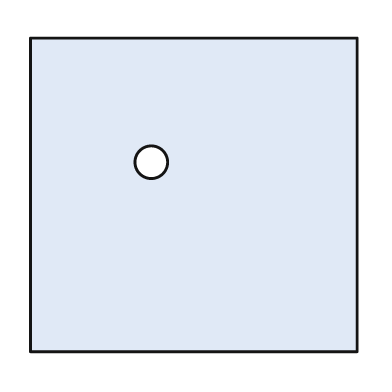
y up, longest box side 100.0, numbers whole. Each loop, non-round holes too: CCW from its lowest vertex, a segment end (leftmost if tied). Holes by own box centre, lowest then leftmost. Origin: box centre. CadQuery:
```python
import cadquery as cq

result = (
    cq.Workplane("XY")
    .moveTo(-50.0, -48.0)
    .lineTo(50.0, -48.0)
    .lineTo(50.0, 48.0)
    .lineTo(-50.0, 48.0)
    .close()
    .moveTo(-13.0, 10.0)
    .circle(5.0)
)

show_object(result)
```